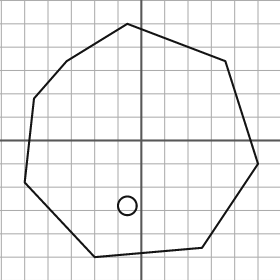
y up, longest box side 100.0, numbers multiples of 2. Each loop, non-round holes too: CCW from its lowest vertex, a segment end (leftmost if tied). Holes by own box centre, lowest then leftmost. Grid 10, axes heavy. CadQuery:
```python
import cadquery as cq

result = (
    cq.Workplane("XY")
    .moveTo(-20.0, -50.0)
    .lineTo(26.0, -46.0)
    .lineTo(50.0, -10.0)
    .lineTo(36.0, 34.0)
    .lineTo(-6.0, 50.0)
    .lineTo(-32.0, 34.0)
    .lineTo(-46.0, 18.0)
    .lineTo(-50.0, -18.0)
    .close()
    .moveTo(-6.0, -28.0)
    .circle(4.0)
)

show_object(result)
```